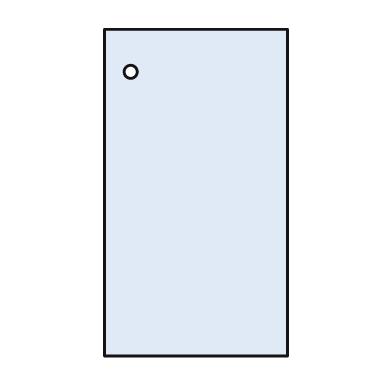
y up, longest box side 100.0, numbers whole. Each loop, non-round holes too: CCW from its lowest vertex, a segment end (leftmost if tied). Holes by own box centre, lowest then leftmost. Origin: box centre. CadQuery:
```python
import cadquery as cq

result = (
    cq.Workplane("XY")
    .moveTo(-28.0, -50.0)
    .lineTo(28.0, -50.0)
    .lineTo(28.0, 50.0)
    .lineTo(-28.0, 50.0)
    .close()
    .moveTo(-20.0, 37.0)
    .circle(2.0)
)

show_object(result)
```